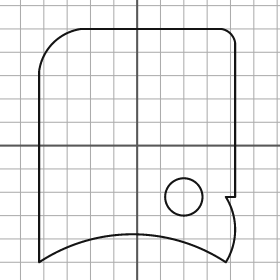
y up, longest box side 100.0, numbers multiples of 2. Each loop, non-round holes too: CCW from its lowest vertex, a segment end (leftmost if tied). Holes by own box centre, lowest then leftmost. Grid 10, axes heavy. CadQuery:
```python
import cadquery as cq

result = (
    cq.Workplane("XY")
    .moveTo(-42.0, -50.0)
    .threePointArc((-2.0, -38.0), (38.0, -50.0))
    .threePointArc((42.0, -36.0), (38.0, -22.0))
    .lineTo(42.0, -22.0)
    .lineTo(42.0, 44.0)
    .threePointArc((40.0, 48.0), (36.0, 50.0))
    .lineTo(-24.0, 50.0)
    .threePointArc((-36.0, 44.0), (-42.0, 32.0))
    .close()
    .moveTo(20.0, -22.0)
    .circle(8.0)
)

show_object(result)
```